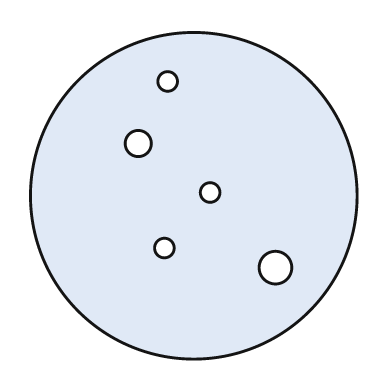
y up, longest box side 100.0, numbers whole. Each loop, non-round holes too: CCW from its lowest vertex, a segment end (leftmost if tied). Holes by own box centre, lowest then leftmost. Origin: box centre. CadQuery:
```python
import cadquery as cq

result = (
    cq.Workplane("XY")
    .moveTo(0.0, 0.0)
    .circle(50.0)
    .moveTo(25.0, -22.0)
    .circle(5.0)
    .moveTo(-9.0, -16.0)
    .circle(3.0)
    .moveTo(5.0, 1.0)
    .circle(3.0)
    .moveTo(-17.0, 16.0)
    .circle(4.0)
    .moveTo(-8.0, 35.0)
    .circle(3.0)
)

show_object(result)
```